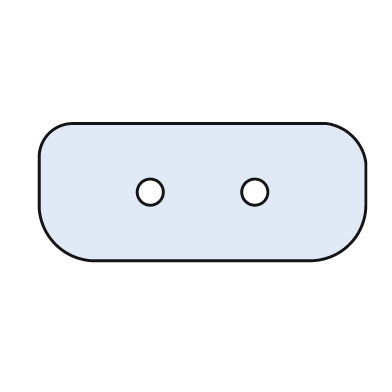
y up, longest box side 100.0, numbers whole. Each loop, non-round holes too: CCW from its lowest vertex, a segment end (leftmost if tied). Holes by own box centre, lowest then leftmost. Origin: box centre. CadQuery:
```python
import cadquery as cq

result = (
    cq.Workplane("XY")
    .moveTo(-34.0, -21.0)
    .lineTo(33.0, -21.0)
    .threePointArc((45.0, -16.0), (50.0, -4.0))
    .lineTo(50.0, 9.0)
    .threePointArc((46.0, 17.0), (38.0, 21.0))
    .lineTo(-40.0, 21.0)
    .threePointArc((-47.0, 18.0), (-50.0, 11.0))
    .lineTo(-50.0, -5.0)
    .threePointArc((-45.0, -16.0), (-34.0, -21.0))
    .close()
    .moveTo(-16.0, 0.0)
    .circle(4.0)
    .moveTo(16.0, 0.0)
    .circle(4.0)
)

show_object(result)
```